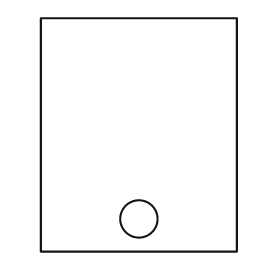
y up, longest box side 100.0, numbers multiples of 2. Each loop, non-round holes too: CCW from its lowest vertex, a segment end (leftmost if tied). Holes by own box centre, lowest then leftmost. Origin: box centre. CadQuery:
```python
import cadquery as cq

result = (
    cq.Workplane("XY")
    .moveTo(-42.0, -50.0)
    .lineTo(42.0, -50.0)
    .lineTo(42.0, 50.0)
    .lineTo(-42.0, 50.0)
    .close()
    .moveTo(0.0, -36.0)
    .circle(8.0)
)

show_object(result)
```